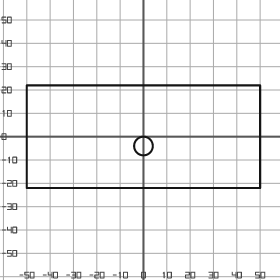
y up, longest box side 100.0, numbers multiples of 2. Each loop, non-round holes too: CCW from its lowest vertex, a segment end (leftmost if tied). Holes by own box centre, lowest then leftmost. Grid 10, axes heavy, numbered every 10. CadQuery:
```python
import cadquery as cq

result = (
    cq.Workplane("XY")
    .moveTo(-50.0, -22.0)
    .lineTo(50.0, -22.0)
    .lineTo(50.0, 22.0)
    .lineTo(-50.0, 22.0)
    .close()
    .moveTo(0.0, -4.0)
    .circle(4.0)
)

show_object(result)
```